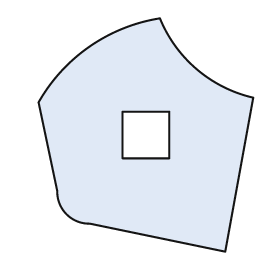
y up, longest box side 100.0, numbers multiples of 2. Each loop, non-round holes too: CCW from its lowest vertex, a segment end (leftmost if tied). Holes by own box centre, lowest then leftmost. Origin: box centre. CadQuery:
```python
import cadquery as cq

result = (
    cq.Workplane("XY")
    .moveTo(34.0, -50.0)
    .lineTo(46.0, 16.0)
    .threePointArc((22.0, 28.0), (6.0, 50.0))
    .threePointArc((-24.0, 38.0), (-46.0, 14.0))
    .lineTo(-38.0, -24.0)
    .threePointArc((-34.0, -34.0), (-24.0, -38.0))
    .close()
    .moveTo(-10.0, -10.0)
    .lineTo(10.0, -10.0)
    .lineTo(10.0, 10.0)
    .lineTo(-10.0, 10.0)
    .close()
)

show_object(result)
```